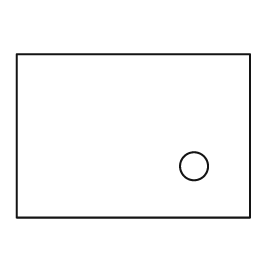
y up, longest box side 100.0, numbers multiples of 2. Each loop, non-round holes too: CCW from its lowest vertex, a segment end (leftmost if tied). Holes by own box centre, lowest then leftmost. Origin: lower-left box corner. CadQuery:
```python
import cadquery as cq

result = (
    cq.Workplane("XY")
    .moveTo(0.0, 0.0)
    .lineTo(100.0, 0.0)
    .lineTo(100.0, 70.0)
    .lineTo(0.0, 70.0)
    .close()
    .moveTo(76.0, 22.0)
    .circle(6.0)
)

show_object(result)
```